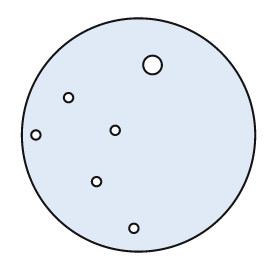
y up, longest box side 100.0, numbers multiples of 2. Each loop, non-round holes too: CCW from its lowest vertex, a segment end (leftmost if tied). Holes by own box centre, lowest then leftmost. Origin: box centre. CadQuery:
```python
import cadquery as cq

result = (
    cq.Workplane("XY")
    .moveTo(0.0, 0.0)
    .circle(50.0)
    .moveTo(-2.0, -40.0)
    .circle(2.0)
    .moveTo(-18.0, -20.0)
    .circle(2.0)
    .moveTo(-44.0, 0.0)
    .circle(2.0)
    .moveTo(-10.0, 2.0)
    .circle(2.0)
    .moveTo(-30.0, 16.0)
    .circle(2.0)
    .moveTo(6.0, 30.0)
    .circle(4.0)
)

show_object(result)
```